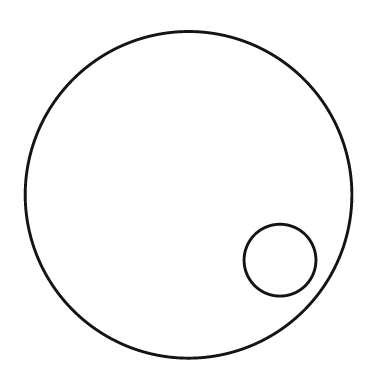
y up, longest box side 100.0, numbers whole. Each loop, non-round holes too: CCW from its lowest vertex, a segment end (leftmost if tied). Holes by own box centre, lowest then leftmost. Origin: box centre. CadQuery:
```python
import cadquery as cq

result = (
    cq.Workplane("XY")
    .moveTo(0.0, 0.0)
    .circle(50.0)
    .moveTo(28.0, -20.0)
    .circle(11.0)
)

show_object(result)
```